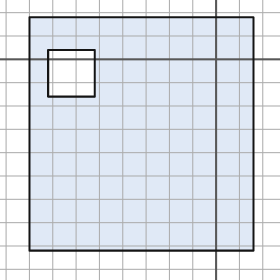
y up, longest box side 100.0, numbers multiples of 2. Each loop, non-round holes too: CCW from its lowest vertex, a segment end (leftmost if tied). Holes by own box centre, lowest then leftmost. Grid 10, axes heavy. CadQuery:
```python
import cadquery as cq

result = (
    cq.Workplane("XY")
    .moveTo(-80.0, -82.0)
    .lineTo(16.0, -82.0)
    .lineTo(16.0, 18.0)
    .lineTo(-80.0, 18.0)
    .close()
    .moveTo(-72.0, -16.0)
    .lineTo(-52.0, -16.0)
    .lineTo(-52.0, 4.0)
    .lineTo(-72.0, 4.0)
    .close()
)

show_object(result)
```